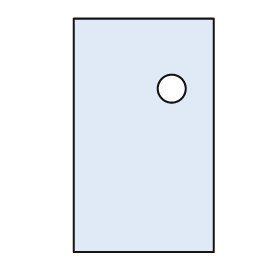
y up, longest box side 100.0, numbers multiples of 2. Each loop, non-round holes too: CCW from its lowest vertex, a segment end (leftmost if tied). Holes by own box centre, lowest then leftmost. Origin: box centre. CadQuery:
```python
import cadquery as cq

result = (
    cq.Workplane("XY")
    .moveTo(-30.0, -50.0)
    .lineTo(30.0, -50.0)
    .lineTo(30.0, 50.0)
    .lineTo(-30.0, 50.0)
    .close()
    .moveTo(12.0, 20.0)
    .circle(6.0)
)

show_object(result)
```